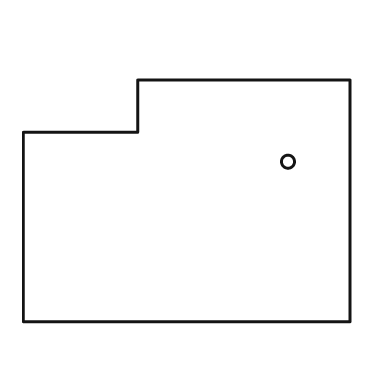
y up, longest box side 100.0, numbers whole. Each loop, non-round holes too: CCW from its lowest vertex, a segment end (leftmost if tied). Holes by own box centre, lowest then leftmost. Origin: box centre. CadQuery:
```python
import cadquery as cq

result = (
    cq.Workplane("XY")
    .moveTo(-50.0, -37.0)
    .lineTo(50.0, -37.0)
    .lineTo(50.0, 37.0)
    .lineTo(-15.0, 37.0)
    .lineTo(-15.0, 21.0)
    .lineTo(-50.0, 21.0)
    .close()
    .moveTo(31.0, 12.0)
    .circle(2.0)
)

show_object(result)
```